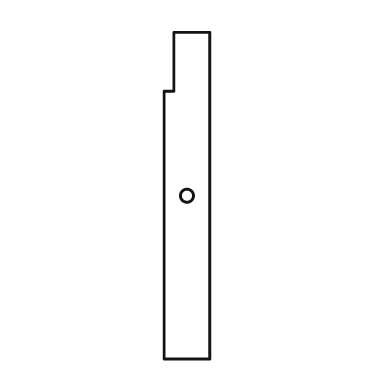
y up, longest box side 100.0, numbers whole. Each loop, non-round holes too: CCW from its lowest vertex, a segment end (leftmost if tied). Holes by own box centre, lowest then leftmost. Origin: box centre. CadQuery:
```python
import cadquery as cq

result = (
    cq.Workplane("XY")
    .moveTo(-7.0, -50.0)
    .lineTo(7.0, -50.0)
    .lineTo(7.0, 50.0)
    .lineTo(-4.0, 50.0)
    .lineTo(-4.0, 32.0)
    .lineTo(-7.0, 32.0)
    .close()
    .moveTo(0.0, 0.0)
    .circle(2.0)
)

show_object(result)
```